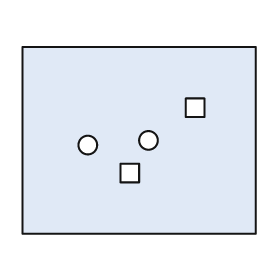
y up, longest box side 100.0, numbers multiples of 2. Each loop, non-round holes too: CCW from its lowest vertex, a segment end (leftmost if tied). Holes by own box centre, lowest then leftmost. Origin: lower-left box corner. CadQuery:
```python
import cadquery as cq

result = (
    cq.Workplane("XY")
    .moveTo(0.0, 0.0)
    .lineTo(100.0, 0.0)
    .lineTo(100.0, 80.0)
    .lineTo(0.0, 80.0)
    .close()
    .moveTo(42.0, 22.0)
    .lineTo(50.0, 22.0)
    .lineTo(50.0, 30.0)
    .lineTo(42.0, 30.0)
    .close()
    .moveTo(28.0, 38.0)
    .circle(4.0)
    .moveTo(54.0, 40.0)
    .circle(4.0)
    .moveTo(70.0, 50.0)
    .lineTo(78.0, 50.0)
    .lineTo(78.0, 58.0)
    .lineTo(70.0, 58.0)
    .close()
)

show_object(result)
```